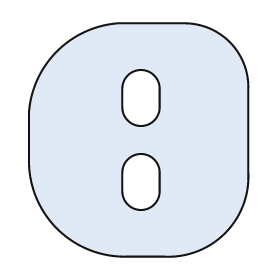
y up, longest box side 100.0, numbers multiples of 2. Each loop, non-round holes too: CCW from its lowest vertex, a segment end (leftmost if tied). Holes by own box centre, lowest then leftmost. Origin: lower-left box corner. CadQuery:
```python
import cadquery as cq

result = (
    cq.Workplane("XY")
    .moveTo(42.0, 0.0)
    .lineTo(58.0, 0.0)
    .threePointArc((84.0, 10.0), (94.0, 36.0))
    .lineTo(94.0, 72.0)
    .threePointArc((86.0, 92.0), (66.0, 100.0))
    .lineTo(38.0, 100.0)
    .threePointArc((12.0, 88.0), (0.0, 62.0))
    .lineTo(0.0, 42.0)
    .threePointArc((12.0, 12.0), (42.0, 0.0))
    .close()
    .moveTo(40.0, 28.0)
    .threePointArc((48.0, 20.0), (56.0, 28.0))
    .lineTo(56.0, 36.0)
    .threePointArc((48.0, 44.0), (40.0, 36.0))
    .close()
    .moveTo(40.0, 64.0)
    .threePointArc((48.0, 56.0), (56.0, 64.0))
    .lineTo(56.0, 72.0)
    .threePointArc((48.0, 80.0), (40.0, 72.0))
    .close()
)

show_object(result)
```